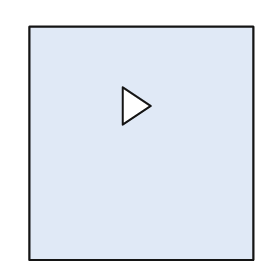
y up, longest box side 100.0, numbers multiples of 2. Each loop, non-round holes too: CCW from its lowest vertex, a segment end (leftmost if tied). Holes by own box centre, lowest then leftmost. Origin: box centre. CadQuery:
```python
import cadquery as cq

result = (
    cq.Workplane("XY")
    .moveTo(-48.0, -50.0)
    .lineTo(48.0, -50.0)
    .lineTo(48.0, 50.0)
    .lineTo(-48.0, 50.0)
    .close()
    .moveTo(-8.0, 8.0)
    .lineTo(4.0, 16.0)
    .lineTo(-8.0, 24.0)
    .close()
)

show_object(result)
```